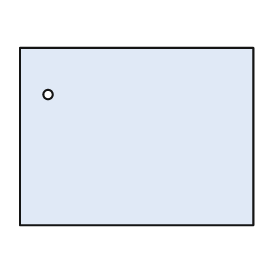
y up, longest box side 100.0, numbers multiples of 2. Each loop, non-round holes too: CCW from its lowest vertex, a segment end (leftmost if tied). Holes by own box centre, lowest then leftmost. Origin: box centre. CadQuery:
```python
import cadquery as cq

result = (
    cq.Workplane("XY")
    .moveTo(-50.0, -38.0)
    .lineTo(50.0, -38.0)
    .lineTo(50.0, 38.0)
    .lineTo(-50.0, 38.0)
    .close()
    .moveTo(-38.0, 18.0)
    .circle(2.0)
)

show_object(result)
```